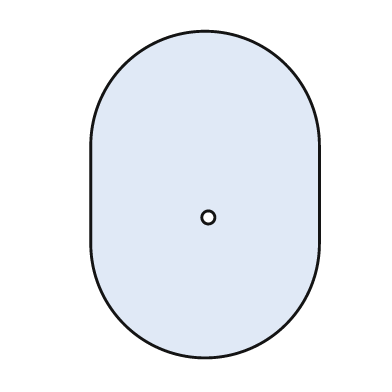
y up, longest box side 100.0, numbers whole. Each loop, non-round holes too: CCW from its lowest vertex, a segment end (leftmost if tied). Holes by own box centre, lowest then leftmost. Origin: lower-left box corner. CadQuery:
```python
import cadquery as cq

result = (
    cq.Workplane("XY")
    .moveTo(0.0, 35.0)
    .threePointArc((35.0, 0.0), (70.0, 35.0))
    .lineTo(70.0, 65.0)
    .threePointArc((35.0, 100.0), (0.0, 65.0))
    .close()
    .moveTo(36.0, 43.0)
    .circle(2.0)
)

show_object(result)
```